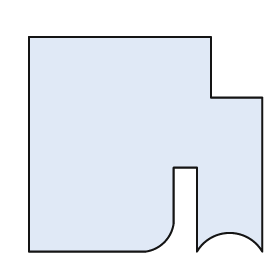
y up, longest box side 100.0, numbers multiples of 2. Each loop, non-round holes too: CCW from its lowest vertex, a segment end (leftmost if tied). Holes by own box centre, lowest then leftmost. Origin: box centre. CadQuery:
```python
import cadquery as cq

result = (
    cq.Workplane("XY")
    .moveTo(-50.0, -46.0)
    .lineTo(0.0, -46.0)
    .threePointArc((8.0, -42.0), (12.0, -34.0))
    .lineTo(12.0, -10.0)
    .lineTo(22.0, -10.0)
    .lineTo(22.0, -46.0)
    .threePointArc((36.0, -38.0), (50.0, -46.0))
    .lineTo(50.0, 20.0)
    .lineTo(28.0, 20.0)
    .lineTo(28.0, 46.0)
    .lineTo(-50.0, 46.0)
    .close()
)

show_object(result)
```